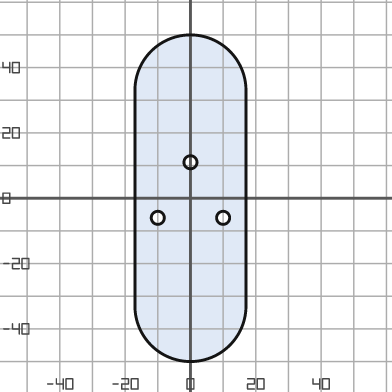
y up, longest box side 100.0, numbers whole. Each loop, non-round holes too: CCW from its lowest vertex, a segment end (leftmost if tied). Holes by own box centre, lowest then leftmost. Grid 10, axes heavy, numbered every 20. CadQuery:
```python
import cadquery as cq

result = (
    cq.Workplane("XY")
    .moveTo(-17.0, -33.0)
    .threePointArc((0.0, -50.0), (17.0, -33.0))
    .lineTo(17.0, 33.0)
    .threePointArc((0.0, 50.0), (-17.0, 33.0))
    .close()
    .moveTo(-10.0, -6.0)
    .circle(2.0)
    .moveTo(10.0, -6.0)
    .circle(2.0)
    .moveTo(0.0, 11.0)
    .circle(2.0)
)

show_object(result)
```